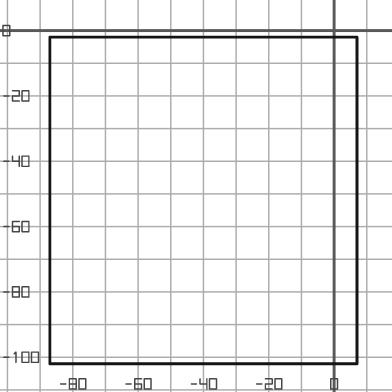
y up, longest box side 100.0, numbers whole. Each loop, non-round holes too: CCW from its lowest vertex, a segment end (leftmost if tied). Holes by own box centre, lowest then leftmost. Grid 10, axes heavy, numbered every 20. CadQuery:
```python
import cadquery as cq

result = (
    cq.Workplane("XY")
    .moveTo(-87.0, -102.0)
    .lineTo(7.0, -102.0)
    .lineTo(7.0, -2.0)
    .lineTo(-87.0, -2.0)
    .close()
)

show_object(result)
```